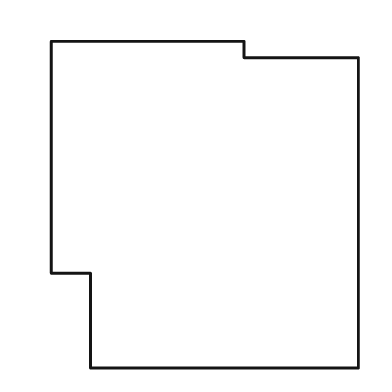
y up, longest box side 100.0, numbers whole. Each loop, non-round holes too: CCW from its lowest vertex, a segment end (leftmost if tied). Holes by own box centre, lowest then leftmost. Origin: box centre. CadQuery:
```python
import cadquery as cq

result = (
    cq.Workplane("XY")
    .moveTo(-35.0, -50.0)
    .lineTo(47.0, -50.0)
    .lineTo(47.0, 45.0)
    .lineTo(12.0, 45.0)
    .lineTo(12.0, 50.0)
    .lineTo(-47.0, 50.0)
    .lineTo(-47.0, -21.0)
    .lineTo(-35.0, -21.0)
    .close()
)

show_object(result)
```